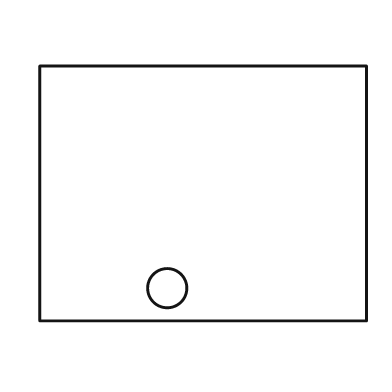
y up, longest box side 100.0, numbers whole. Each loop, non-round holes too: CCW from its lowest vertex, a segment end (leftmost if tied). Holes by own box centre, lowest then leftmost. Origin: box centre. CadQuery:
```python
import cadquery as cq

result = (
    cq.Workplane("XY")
    .moveTo(-50.0, -39.0)
    .lineTo(50.0, -39.0)
    .lineTo(50.0, 39.0)
    .lineTo(-50.0, 39.0)
    .close()
    .moveTo(-11.0, -29.0)
    .circle(6.0)
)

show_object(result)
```